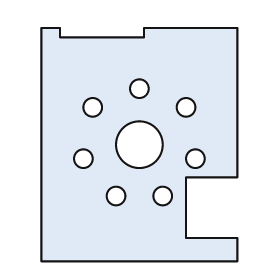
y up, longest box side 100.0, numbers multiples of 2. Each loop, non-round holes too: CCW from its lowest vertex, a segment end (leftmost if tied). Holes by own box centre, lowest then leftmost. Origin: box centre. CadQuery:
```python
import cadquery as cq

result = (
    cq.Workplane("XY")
    .moveTo(-42.0, -50.0)
    .lineTo(42.0, -50.0)
    .lineTo(42.0, -40.0)
    .lineTo(20.0, -40.0)
    .lineTo(20.0, -14.0)
    .lineTo(42.0, -14.0)
    .lineTo(42.0, 50.0)
    .lineTo(2.0, 50.0)
    .lineTo(2.0, 46.0)
    .lineTo(-34.0, 46.0)
    .lineTo(-34.0, 50.0)
    .lineTo(-42.0, 50.0)
    .close()
    .moveTo(-10.0, -22.0)
    .circle(4.0)
    .moveTo(10.0, -22.0)
    .circle(4.0)
    .moveTo(-24.0, -6.0)
    .circle(4.0)
    .moveTo(24.0, -6.0)
    .circle(4.0)
    .moveTo(0.0, 0.0)
    .circle(10.0)
    .moveTo(-20.0, 16.0)
    .circle(4.0)
    .moveTo(20.0, 16.0)
    .circle(4.0)
    .moveTo(0.0, 24.0)
    .circle(4.0)
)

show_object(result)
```